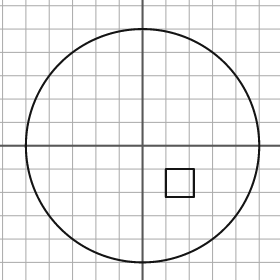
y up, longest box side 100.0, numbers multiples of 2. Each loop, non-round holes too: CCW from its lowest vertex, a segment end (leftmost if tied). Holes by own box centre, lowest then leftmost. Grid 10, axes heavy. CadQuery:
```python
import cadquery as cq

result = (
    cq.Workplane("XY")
    .moveTo(0.0, 0.0)
    .circle(50.0)
    .moveTo(10.0, -22.0)
    .lineTo(22.0, -22.0)
    .lineTo(22.0, -10.0)
    .lineTo(10.0, -10.0)
    .close()
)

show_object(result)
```